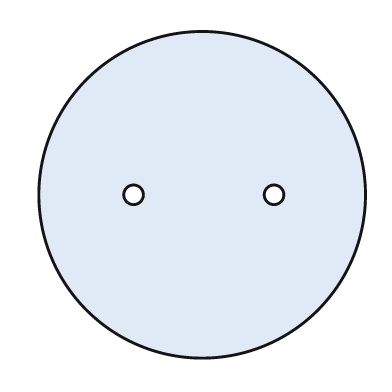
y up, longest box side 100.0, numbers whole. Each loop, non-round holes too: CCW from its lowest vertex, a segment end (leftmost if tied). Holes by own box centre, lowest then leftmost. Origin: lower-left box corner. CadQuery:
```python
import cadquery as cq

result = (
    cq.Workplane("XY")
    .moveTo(50.0, 50.0)
    .circle(50.0)
    .moveTo(29.0, 50.0)
    .circle(3.0)
    .moveTo(72.0, 50.0)
    .circle(3.0)
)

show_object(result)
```